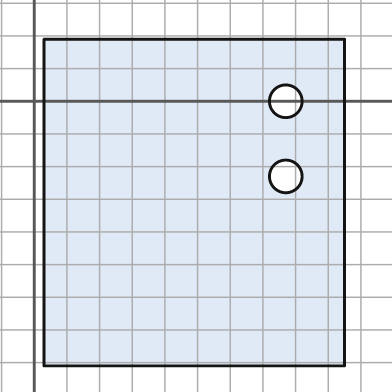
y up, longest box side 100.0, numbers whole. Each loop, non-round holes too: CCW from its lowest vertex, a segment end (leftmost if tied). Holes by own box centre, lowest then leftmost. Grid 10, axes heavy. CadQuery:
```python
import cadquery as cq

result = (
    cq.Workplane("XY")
    .moveTo(3.0, -81.0)
    .lineTo(95.0, -81.0)
    .lineTo(95.0, 19.0)
    .lineTo(3.0, 19.0)
    .close()
    .moveTo(77.0, -23.0)
    .circle(5.0)
    .moveTo(77.0, 0.0)
    .circle(5.0)
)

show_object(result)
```